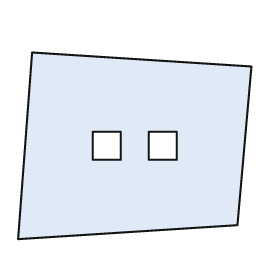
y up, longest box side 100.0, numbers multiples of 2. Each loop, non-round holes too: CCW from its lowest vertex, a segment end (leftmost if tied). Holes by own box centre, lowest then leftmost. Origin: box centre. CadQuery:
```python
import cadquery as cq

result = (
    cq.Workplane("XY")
    .moveTo(-50.0, -40.0)
    .lineTo(44.0, -34.0)
    .lineTo(50.0, 34.0)
    .lineTo(-44.0, 40.0)
    .close()
    .moveTo(-18.0, -6.0)
    .lineTo(-6.0, -6.0)
    .lineTo(-6.0, 6.0)
    .lineTo(-18.0, 6.0)
    .close()
    .moveTo(6.0, -6.0)
    .lineTo(18.0, -6.0)
    .lineTo(18.0, 6.0)
    .lineTo(6.0, 6.0)
    .close()
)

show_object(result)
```